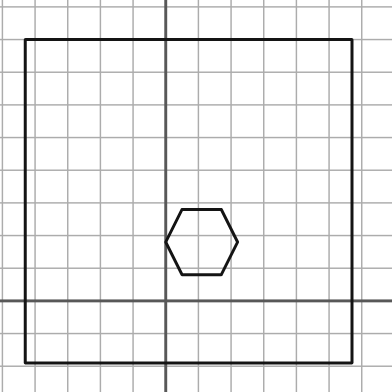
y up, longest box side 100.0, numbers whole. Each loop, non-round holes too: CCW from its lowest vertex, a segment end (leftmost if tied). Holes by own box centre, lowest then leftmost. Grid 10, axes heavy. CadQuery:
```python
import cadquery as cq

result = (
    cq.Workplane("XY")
    .moveTo(-43.0, -19.0)
    .lineTo(57.0, -19.0)
    .lineTo(57.0, 80.0)
    .lineTo(-43.0, 80.0)
    .close()
    .moveTo(5.0, 8.0)
    .lineTo(17.0, 8.0)
    .lineTo(22.0, 18.0)
    .lineTo(17.0, 28.0)
    .lineTo(5.0, 28.0)
    .lineTo(0.0, 18.0)
    .close()
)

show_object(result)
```